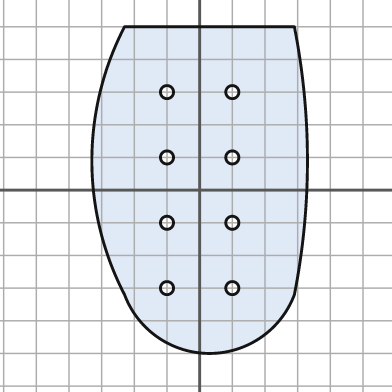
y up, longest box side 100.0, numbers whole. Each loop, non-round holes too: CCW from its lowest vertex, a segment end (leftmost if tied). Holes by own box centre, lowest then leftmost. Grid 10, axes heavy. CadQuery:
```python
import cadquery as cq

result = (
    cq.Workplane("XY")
    .moveTo(-23.0, -32.0)
    .threePointArc((3.0, -50.0), (29.0, -32.0))
    .threePointArc((33.0, 9.0), (29.0, 50.0))
    .lineTo(-23.0, 50.0)
    .threePointArc((-33.0, 9.0), (-23.0, -32.0))
    .close()
    .moveTo(-10.0, -30.0)
    .circle(2.0)
    .moveTo(10.0, -30.0)
    .circle(2.0)
    .moveTo(-10.0, -10.0)
    .circle(2.0)
    .moveTo(10.0, -10.0)
    .circle(2.0)
    .moveTo(-10.0, 10.0)
    .circle(2.0)
    .moveTo(10.0, 10.0)
    .circle(2.0)
    .moveTo(-10.0, 30.0)
    .circle(2.0)
    .moveTo(10.0, 30.0)
    .circle(2.0)
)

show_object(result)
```